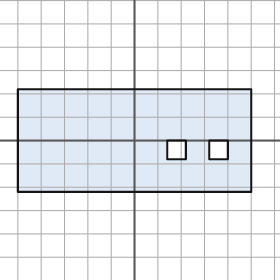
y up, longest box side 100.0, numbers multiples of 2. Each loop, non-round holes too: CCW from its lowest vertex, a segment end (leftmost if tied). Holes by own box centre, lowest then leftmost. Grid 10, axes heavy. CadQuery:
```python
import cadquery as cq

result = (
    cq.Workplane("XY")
    .moveTo(-50.0, -22.0)
    .lineTo(50.0, -22.0)
    .lineTo(50.0, 22.0)
    .lineTo(-50.0, 22.0)
    .close()
    .moveTo(14.0, -8.0)
    .lineTo(22.0, -8.0)
    .lineTo(22.0, 0.0)
    .lineTo(14.0, 0.0)
    .close()
    .moveTo(32.0, -8.0)
    .lineTo(40.0, -8.0)
    .lineTo(40.0, 0.0)
    .lineTo(32.0, 0.0)
    .close()
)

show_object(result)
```